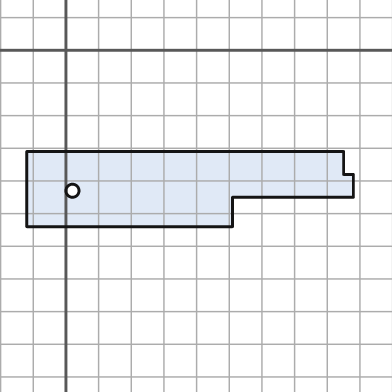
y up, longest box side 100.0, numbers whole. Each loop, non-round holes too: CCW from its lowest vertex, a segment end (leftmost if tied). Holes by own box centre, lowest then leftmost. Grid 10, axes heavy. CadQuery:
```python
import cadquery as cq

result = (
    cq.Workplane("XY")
    .moveTo(-12.0, -54.0)
    .lineTo(51.0, -54.0)
    .lineTo(51.0, -45.0)
    .lineTo(88.0, -45.0)
    .lineTo(88.0, -38.0)
    .lineTo(85.0, -38.0)
    .lineTo(85.0, -31.0)
    .lineTo(-12.0, -31.0)
    .close()
    .moveTo(2.0, -43.0)
    .circle(2.0)
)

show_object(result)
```